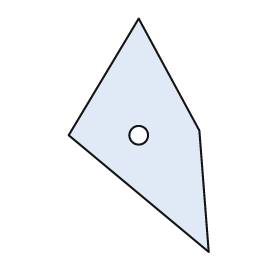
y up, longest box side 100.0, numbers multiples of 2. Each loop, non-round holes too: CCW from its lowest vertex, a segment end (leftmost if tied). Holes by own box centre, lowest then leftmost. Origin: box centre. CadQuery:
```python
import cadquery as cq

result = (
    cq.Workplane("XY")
    .moveTo(30.0, -50.0)
    .lineTo(26.0, 2.0)
    .lineTo(0.0, 50.0)
    .lineTo(-30.0, 0.0)
    .close()
    .moveTo(0.0, 0.0)
    .circle(4.0)
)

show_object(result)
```